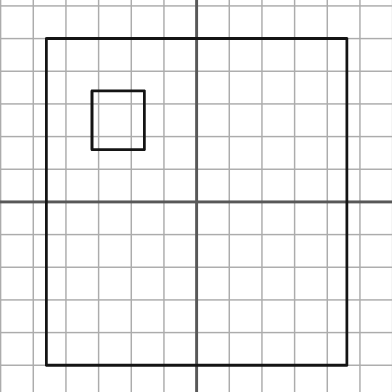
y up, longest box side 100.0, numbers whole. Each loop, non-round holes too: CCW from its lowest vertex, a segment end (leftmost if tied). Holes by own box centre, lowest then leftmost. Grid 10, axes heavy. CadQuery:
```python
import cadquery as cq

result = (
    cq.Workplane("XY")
    .moveTo(-46.0, -50.0)
    .lineTo(46.0, -50.0)
    .lineTo(46.0, 50.0)
    .lineTo(-46.0, 50.0)
    .close()
    .moveTo(-32.0, 16.0)
    .lineTo(-16.0, 16.0)
    .lineTo(-16.0, 34.0)
    .lineTo(-32.0, 34.0)
    .close()
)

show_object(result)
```